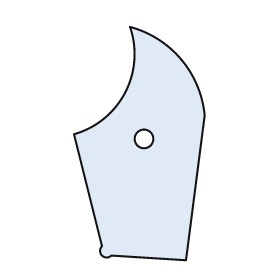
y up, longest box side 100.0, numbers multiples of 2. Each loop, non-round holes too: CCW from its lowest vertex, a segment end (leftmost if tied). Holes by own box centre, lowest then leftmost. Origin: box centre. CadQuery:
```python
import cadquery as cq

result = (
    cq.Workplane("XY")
    .moveTo(20.0, -50.0)
    .lineTo(28.0, 12.0)
    .threePointArc((18.0, 36.0), (-4.0, 50.0))
    .threePointArc((-6.0, 22.0), (-28.0, 4.0))
    .lineTo(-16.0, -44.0)
    .threePointArc((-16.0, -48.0), (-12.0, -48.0))
    .close()
    .moveTo(2.0, 2.0)
    .circle(4.0)
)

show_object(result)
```